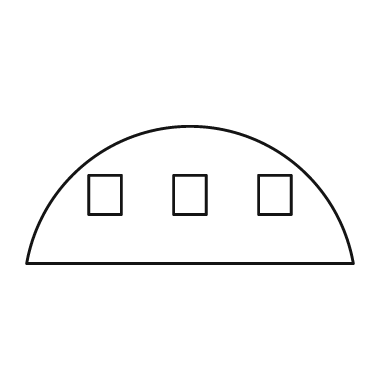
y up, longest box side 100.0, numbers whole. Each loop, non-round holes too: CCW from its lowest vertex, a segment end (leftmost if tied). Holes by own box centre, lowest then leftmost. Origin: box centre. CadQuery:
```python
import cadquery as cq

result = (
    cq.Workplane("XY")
    .moveTo(-50.0, -21.0)
    .lineTo(50.0, -21.0)
    .threePointArc((0.0, 21.0), (-50.0, -21.0))
    .close()
    .moveTo(-31.0, -6.0)
    .lineTo(-21.0, -6.0)
    .lineTo(-21.0, 6.0)
    .lineTo(-31.0, 6.0)
    .close()
    .moveTo(-5.0, -6.0)
    .lineTo(5.0, -6.0)
    .lineTo(5.0, 6.0)
    .lineTo(-5.0, 6.0)
    .close()
    .moveTo(21.0, -6.0)
    .lineTo(31.0, -6.0)
    .lineTo(31.0, 6.0)
    .lineTo(21.0, 6.0)
    .close()
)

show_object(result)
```